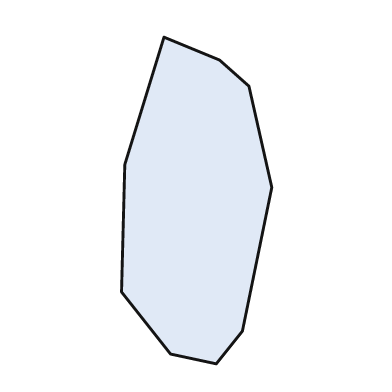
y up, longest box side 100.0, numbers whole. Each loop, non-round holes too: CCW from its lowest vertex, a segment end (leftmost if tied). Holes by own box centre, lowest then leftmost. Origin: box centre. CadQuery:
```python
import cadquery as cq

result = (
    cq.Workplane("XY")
    .moveTo(6.0, -50.0)
    .lineTo(14.0, -40.0)
    .lineTo(23.0, 4.0)
    .lineTo(16.0, 35.0)
    .lineTo(7.0, 43.0)
    .lineTo(-10.0, 50.0)
    .lineTo(-22.0, 11.0)
    .lineTo(-23.0, -28.0)
    .lineTo(-8.0, -47.0)
    .close()
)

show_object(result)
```